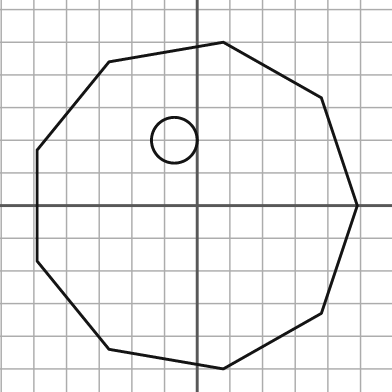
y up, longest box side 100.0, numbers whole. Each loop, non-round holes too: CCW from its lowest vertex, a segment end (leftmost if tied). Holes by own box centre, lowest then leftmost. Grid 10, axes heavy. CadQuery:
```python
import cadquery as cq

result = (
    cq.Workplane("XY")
    .moveTo(8.0, -50.0)
    .lineTo(38.0, -33.0)
    .lineTo(49.0, 0.0)
    .lineTo(38.0, 33.0)
    .lineTo(8.0, 50.0)
    .lineTo(-27.0, 44.0)
    .lineTo(-49.0, 17.0)
    .lineTo(-49.0, -17.0)
    .lineTo(-27.0, -44.0)
    .close()
    .moveTo(-7.0, 20.0)
    .circle(7.0)
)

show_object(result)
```